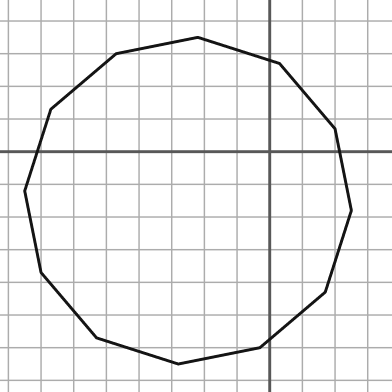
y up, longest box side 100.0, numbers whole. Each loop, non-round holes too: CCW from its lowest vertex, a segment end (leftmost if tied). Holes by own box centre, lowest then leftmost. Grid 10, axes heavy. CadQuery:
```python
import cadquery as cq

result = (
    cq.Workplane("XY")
    .moveTo(-28.0, -65.0)
    .lineTo(-3.0, -60.0)
    .lineTo(17.0, -43.0)
    .lineTo(25.0, -18.0)
    .lineTo(20.0, 7.0)
    .lineTo(3.0, 27.0)
    .lineTo(-22.0, 35.0)
    .lineTo(-47.0, 30.0)
    .lineTo(-67.0, 13.0)
    .lineTo(-75.0, -12.0)
    .lineTo(-70.0, -37.0)
    .lineTo(-53.0, -57.0)
    .close()
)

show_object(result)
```